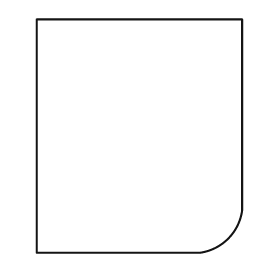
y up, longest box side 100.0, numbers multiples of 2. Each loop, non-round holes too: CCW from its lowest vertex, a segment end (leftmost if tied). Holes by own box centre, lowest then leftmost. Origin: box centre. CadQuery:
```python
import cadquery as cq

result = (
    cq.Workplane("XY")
    .moveTo(-44.0, -50.0)
    .lineTo(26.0, -50.0)
    .threePointArc((38.0, -44.0), (44.0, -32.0))
    .lineTo(44.0, 50.0)
    .lineTo(-44.0, 50.0)
    .close()
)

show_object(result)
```